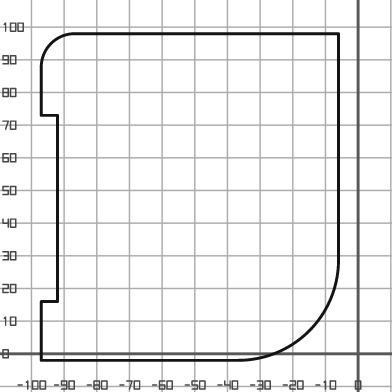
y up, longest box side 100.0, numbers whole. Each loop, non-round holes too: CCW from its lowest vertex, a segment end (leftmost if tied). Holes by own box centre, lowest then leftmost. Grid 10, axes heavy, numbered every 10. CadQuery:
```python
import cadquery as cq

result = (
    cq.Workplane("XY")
    .moveTo(-97.0, -2.0)
    .lineTo(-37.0, -2.0)
    .threePointArc((-15.0, 7.0), (-6.0, 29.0))
    .lineTo(-6.0, 98.0)
    .lineTo(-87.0, 98.0)
    .threePointArc((-94.0, 95.0), (-97.0, 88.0))
    .lineTo(-97.0, 73.0)
    .lineTo(-92.0, 73.0)
    .lineTo(-92.0, 16.0)
    .lineTo(-97.0, 16.0)
    .close()
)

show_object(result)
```